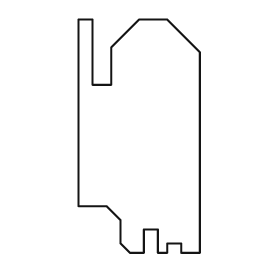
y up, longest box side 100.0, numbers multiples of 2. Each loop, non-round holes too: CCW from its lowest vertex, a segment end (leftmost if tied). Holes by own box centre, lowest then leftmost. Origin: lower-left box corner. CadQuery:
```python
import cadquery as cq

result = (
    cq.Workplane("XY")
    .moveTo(22.0, 0.0)
    .lineTo(28.0, 0.0)
    .lineTo(28.0, 10.0)
    .lineTo(34.0, 10.0)
    .lineTo(34.0, 0.0)
    .lineTo(38.0, 0.0)
    .lineTo(38.0, 4.0)
    .lineTo(44.0, 4.0)
    .lineTo(44.0, 0.0)
    .lineTo(52.0, 0.0)
    .lineTo(52.0, 86.0)
    .lineTo(38.0, 100.0)
    .lineTo(26.0, 100.0)
    .lineTo(14.0, 88.0)
    .lineTo(14.0, 72.0)
    .lineTo(6.0, 72.0)
    .lineTo(6.0, 100.0)
    .lineTo(0.0, 100.0)
    .lineTo(0.0, 20.0)
    .lineTo(12.0, 20.0)
    .lineTo(18.0, 14.0)
    .lineTo(18.0, 4.0)
    .close()
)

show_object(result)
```